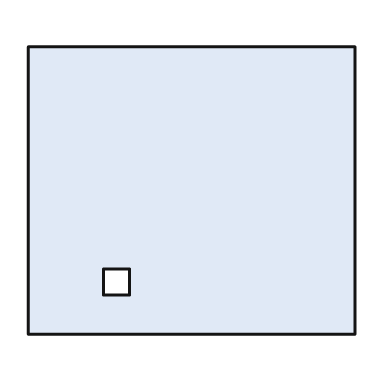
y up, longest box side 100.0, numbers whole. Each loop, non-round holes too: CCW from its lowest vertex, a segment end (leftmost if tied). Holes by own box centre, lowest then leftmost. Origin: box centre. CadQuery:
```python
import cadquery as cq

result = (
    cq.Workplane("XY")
    .moveTo(-50.0, -44.0)
    .lineTo(50.0, -44.0)
    .lineTo(50.0, 44.0)
    .lineTo(-50.0, 44.0)
    .close()
    .moveTo(-27.0, -32.0)
    .lineTo(-19.0, -32.0)
    .lineTo(-19.0, -24.0)
    .lineTo(-27.0, -24.0)
    .close()
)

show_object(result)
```